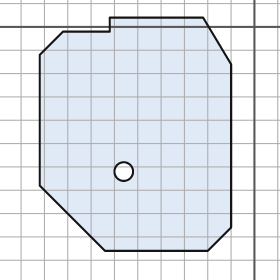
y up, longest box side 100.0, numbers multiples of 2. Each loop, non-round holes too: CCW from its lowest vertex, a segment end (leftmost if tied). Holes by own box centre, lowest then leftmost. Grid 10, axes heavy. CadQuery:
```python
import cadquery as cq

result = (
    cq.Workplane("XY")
    .moveTo(-64.0, -96.0)
    .lineTo(-20.0, -96.0)
    .lineTo(-10.0, -86.0)
    .lineTo(-10.0, -16.0)
    .lineTo(-22.0, 4.0)
    .lineTo(-62.0, 4.0)
    .lineTo(-62.0, -2.0)
    .lineTo(-82.0, -2.0)
    .lineTo(-92.0, -12.0)
    .lineTo(-92.0, -68.0)
    .close()
    .moveTo(-56.0, -62.0)
    .circle(4.0)
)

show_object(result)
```